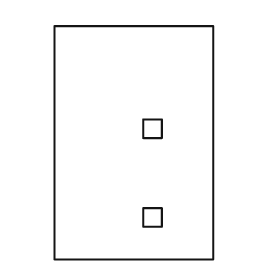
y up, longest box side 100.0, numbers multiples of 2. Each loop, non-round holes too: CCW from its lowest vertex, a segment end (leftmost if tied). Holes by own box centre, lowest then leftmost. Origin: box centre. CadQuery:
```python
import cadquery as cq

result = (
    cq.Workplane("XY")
    .moveTo(-34.0, -50.0)
    .lineTo(34.0, -50.0)
    .lineTo(34.0, 50.0)
    .lineTo(-34.0, 50.0)
    .close()
    .moveTo(4.0, -36.0)
    .lineTo(12.0, -36.0)
    .lineTo(12.0, -28.0)
    .lineTo(4.0, -28.0)
    .close()
    .moveTo(4.0, 2.0)
    .lineTo(12.0, 2.0)
    .lineTo(12.0, 10.0)
    .lineTo(4.0, 10.0)
    .close()
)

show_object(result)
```